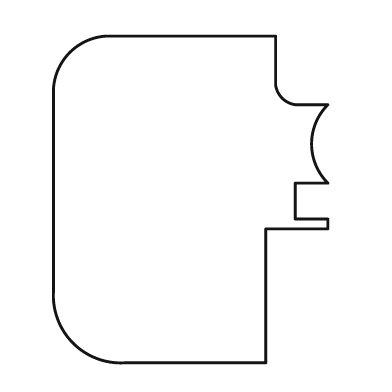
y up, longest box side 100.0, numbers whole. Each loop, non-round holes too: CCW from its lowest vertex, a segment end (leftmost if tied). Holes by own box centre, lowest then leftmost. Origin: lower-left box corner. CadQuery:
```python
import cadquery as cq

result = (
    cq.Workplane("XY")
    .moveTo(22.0, 0.0)
    .lineTo(65.0, 0.0)
    .lineTo(65.0, 41.0)
    .lineTo(84.0, 41.0)
    .lineTo(84.0, 44.0)
    .lineTo(74.0, 44.0)
    .lineTo(74.0, 55.0)
    .lineTo(84.0, 55.0)
    .threePointArc((79.0, 67.0), (84.0, 79.0))
    .lineTo(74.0, 79.0)
    .threePointArc((70.0, 81.0), (68.0, 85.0))
    .lineTo(68.0, 100.0)
    .lineTo(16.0, 100.0)
    .threePointArc((5.0, 95.0), (0.0, 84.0))
    .lineTo(0.0, 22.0)
    .threePointArc((6.0, 6.0), (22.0, 0.0))
    .close()
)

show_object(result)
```